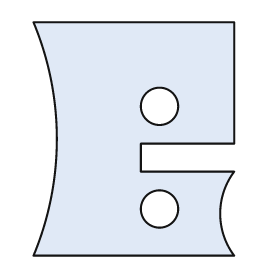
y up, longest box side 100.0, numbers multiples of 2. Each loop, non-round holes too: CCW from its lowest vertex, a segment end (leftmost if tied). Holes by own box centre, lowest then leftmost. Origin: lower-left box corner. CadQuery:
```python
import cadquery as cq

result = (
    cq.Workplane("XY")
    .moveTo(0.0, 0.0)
    .lineTo(86.0, 0.0)
    .threePointArc((80.0, 18.0), (86.0, 36.0))
    .lineTo(46.0, 36.0)
    .lineTo(46.0, 48.0)
    .lineTo(86.0, 48.0)
    .lineTo(86.0, 100.0)
    .lineTo(0.0, 100.0)
    .threePointArc((10.0, 50.0), (0.0, 0.0))
    .close()
    .moveTo(54.0, 20.0)
    .circle(8.0)
    .moveTo(54.0, 64.0)
    .circle(8.0)
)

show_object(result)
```